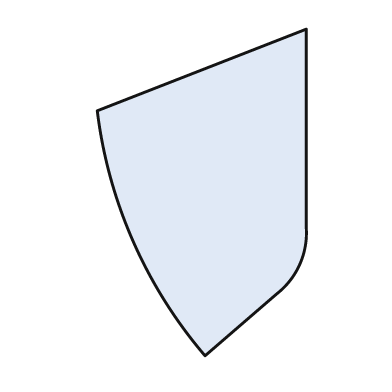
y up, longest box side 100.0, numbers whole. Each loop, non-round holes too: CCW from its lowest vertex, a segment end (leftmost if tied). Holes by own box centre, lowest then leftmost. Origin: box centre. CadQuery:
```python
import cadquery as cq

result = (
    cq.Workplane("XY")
    .moveTo(1.0, -50.0)
    .lineTo(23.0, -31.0)
    .threePointArc((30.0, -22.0), (32.0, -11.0))
    .lineTo(32.0, 50.0)
    .lineTo(-32.0, 25.0)
    .threePointArc((-21.0, -15.0), (1.0, -50.0))
    .close()
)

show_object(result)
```